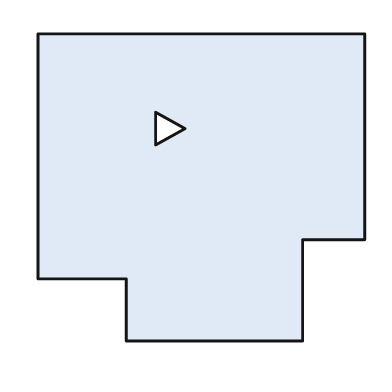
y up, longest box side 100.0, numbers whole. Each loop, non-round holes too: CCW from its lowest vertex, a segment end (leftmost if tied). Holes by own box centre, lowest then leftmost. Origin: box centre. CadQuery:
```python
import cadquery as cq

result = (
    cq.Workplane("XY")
    .moveTo(-23.0, -47.0)
    .lineTo(31.0, -47.0)
    .lineTo(31.0, -16.0)
    .lineTo(50.0, -16.0)
    .lineTo(50.0, 47.0)
    .lineTo(-50.0, 47.0)
    .lineTo(-50.0, -28.0)
    .lineTo(-23.0, -28.0)
    .close()
    .moveTo(-14.0, 13.0)
    .lineTo(-5.0, 18.0)
    .lineTo(-14.0, 23.0)
    .close()
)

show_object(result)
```